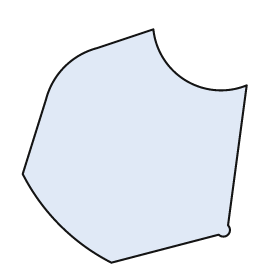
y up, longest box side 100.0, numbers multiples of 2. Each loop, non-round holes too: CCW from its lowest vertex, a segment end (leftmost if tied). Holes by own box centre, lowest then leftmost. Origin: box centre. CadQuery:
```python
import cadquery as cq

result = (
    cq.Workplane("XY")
    .moveTo(-10.0, -50.0)
    .lineTo(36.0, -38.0)
    .threePointArc((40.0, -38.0), (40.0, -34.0))
    .lineTo(48.0, 26.0)
    .threePointArc((22.0, 28.0), (8.0, 50.0))
    .lineTo(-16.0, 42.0)
    .threePointArc((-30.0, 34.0), (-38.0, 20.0))
    .lineTo(-48.0, -12.0)
    .threePointArc((-32.0, -34.0), (-10.0, -50.0))
    .close()
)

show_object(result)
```